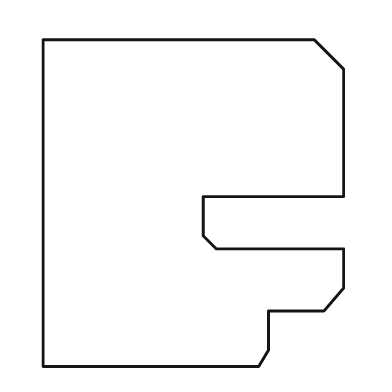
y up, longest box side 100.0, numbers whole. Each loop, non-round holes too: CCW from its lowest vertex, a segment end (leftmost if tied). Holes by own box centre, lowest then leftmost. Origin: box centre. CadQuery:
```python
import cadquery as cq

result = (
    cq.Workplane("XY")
    .moveTo(-46.0, -50.0)
    .lineTo(20.0, -50.0)
    .lineTo(23.0, -45.0)
    .lineTo(23.0, -33.0)
    .lineTo(40.0, -33.0)
    .lineTo(46.0, -26.0)
    .lineTo(46.0, -14.0)
    .lineTo(7.0, -14.0)
    .lineTo(3.0, -10.0)
    .lineTo(3.0, 2.0)
    .lineTo(46.0, 2.0)
    .lineTo(46.0, 41.0)
    .lineTo(37.0, 50.0)
    .lineTo(-46.0, 50.0)
    .close()
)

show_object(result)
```